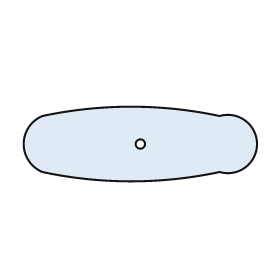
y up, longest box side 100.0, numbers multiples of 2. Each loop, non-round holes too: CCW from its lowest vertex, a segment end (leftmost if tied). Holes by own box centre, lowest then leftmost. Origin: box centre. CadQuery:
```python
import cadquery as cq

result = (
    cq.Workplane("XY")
    .moveTo(-42.0, -12.0)
    .threePointArc((-4.0, -16.0), (34.0, -12.0))
    .threePointArc((50.0, 0.0), (34.0, 12.0))
    .threePointArc((-4.0, 16.0), (-42.0, 12.0))
    .threePointArc((-50.0, 0.0), (-42.0, -12.0))
    .close()
    .moveTo(0.0, 0.0)
    .circle(2.0)
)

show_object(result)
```